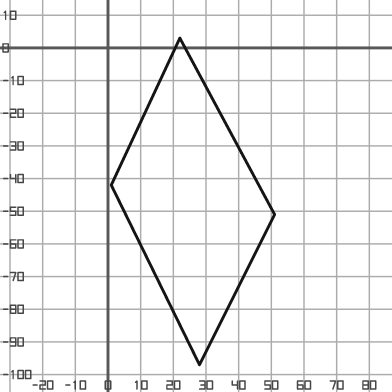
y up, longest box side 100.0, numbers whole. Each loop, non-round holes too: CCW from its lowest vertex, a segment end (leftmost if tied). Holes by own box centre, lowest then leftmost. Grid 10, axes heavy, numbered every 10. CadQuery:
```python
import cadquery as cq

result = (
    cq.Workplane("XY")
    .moveTo(28.0, -97.0)
    .lineTo(51.0, -51.0)
    .lineTo(22.0, 3.0)
    .lineTo(1.0, -42.0)
    .close()
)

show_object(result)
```